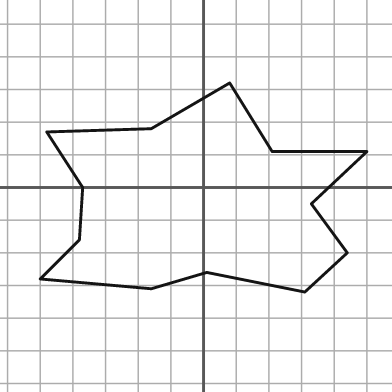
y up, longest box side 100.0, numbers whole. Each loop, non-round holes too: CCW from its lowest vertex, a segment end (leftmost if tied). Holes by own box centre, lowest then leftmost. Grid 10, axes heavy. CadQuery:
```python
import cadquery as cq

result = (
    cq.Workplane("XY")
    .moveTo(31.0, -32.0)
    .lineTo(44.0, -20.0)
    .lineTo(33.0, -5.0)
    .lineTo(50.0, 11.0)
    .lineTo(21.0, 11.0)
    .lineTo(8.0, 32.0)
    .lineTo(-16.0, 18.0)
    .lineTo(-48.0, 17.0)
    .lineTo(-37.0, 0.0)
    .lineTo(-38.0, -16.0)
    .lineTo(-50.0, -28.0)
    .lineTo(-16.0, -31.0)
    .lineTo(1.0, -26.0)
    .close()
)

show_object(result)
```